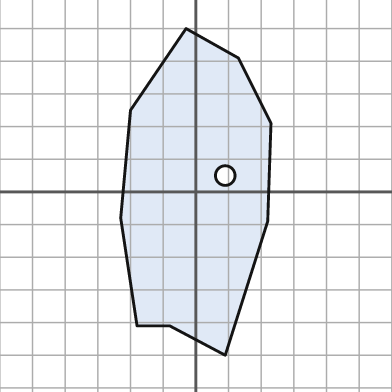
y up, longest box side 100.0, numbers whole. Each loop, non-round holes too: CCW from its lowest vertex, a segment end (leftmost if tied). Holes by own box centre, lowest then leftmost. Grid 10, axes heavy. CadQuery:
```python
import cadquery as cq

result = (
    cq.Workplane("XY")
    .moveTo(9.0, -50.0)
    .lineTo(22.0, -9.0)
    .lineTo(23.0, 21.0)
    .lineTo(13.0, 41.0)
    .lineTo(-3.0, 50.0)
    .lineTo(-20.0, 25.0)
    .lineTo(-23.0, -8.0)
    .lineTo(-18.0, -41.0)
    .lineTo(-8.0, -41.0)
    .close()
    .moveTo(9.0, 5.0)
    .circle(3.0)
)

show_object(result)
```